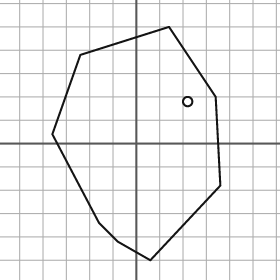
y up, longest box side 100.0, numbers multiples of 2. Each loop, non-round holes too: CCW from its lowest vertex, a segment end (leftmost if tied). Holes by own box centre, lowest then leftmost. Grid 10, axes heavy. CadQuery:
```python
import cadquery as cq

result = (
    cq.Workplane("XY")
    .moveTo(6.0, -50.0)
    .lineTo(36.0, -18.0)
    .lineTo(34.0, 20.0)
    .lineTo(14.0, 50.0)
    .lineTo(-24.0, 38.0)
    .lineTo(-36.0, 4.0)
    .lineTo(-16.0, -34.0)
    .lineTo(-8.0, -42.0)
    .close()
    .moveTo(22.0, 18.0)
    .circle(2.0)
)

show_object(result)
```